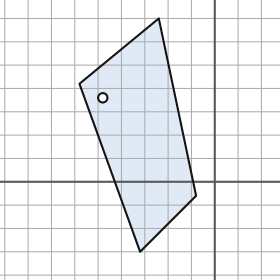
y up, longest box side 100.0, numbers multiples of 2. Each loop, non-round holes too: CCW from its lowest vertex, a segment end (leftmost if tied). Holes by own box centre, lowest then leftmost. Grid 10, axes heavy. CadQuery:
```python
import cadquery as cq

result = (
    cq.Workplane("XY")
    .moveTo(-32.0, -30.0)
    .lineTo(-8.0, -6.0)
    .lineTo(-24.0, 70.0)
    .lineTo(-58.0, 42.0)
    .close()
    .moveTo(-48.0, 36.0)
    .circle(2.0)
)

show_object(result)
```